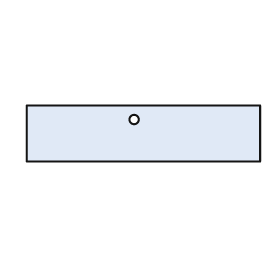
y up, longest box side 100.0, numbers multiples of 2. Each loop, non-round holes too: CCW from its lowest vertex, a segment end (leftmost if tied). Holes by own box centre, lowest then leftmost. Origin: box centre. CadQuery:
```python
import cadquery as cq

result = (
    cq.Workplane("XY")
    .moveTo(-50.0, -12.0)
    .lineTo(50.0, -12.0)
    .lineTo(50.0, 12.0)
    .lineTo(-50.0, 12.0)
    .close()
    .moveTo(-4.0, 6.0)
    .circle(2.0)
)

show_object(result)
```